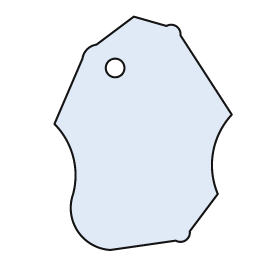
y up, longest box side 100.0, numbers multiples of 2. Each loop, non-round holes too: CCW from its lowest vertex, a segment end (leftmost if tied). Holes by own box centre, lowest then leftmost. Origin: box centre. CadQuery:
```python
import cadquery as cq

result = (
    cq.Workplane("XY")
    .moveTo(-14.0, -50.0)
    .lineTo(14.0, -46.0)
    .threePointArc((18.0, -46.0), (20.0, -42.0))
    .lineTo(32.0, -26.0)
    .threePointArc((30.0, -8.0), (38.0, 8.0))
    .lineTo(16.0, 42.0)
    .threePointArc((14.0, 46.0), (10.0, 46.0))
    .lineTo(-4.0, 50.0)
    .lineTo(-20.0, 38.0)
    .threePointArc((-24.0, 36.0), (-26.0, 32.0))
    .lineTo(-38.0, 4.0)
    .threePointArc((-30.0, -10.0), (-30.0, -26.0))
    .threePointArc((-28.0, -42.0), (-14.0, -50.0))
    .close()
    .moveTo(-12.0, 28.0)
    .circle(4.0)
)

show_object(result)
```